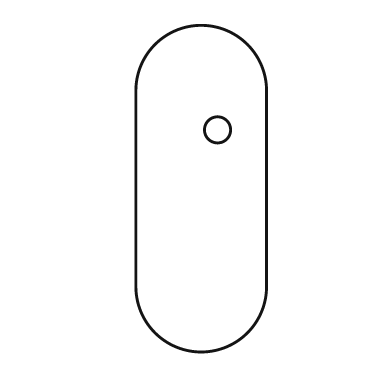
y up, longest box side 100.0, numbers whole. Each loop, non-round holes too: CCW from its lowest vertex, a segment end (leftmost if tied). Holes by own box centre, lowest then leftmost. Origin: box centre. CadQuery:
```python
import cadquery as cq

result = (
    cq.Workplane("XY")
    .moveTo(-20.0, -30.0)
    .threePointArc((0.0, -50.0), (20.0, -30.0))
    .lineTo(20.0, 30.0)
    .threePointArc((0.0, 50.0), (-20.0, 30.0))
    .close()
    .moveTo(5.0, 18.0)
    .circle(4.0)
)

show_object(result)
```